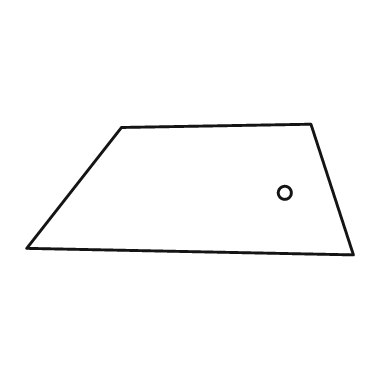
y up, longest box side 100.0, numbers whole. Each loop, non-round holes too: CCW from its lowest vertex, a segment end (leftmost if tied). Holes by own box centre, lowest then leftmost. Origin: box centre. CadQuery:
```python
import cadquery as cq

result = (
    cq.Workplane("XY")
    .moveTo(50.0, -20.0)
    .lineTo(37.0, 20.0)
    .lineTo(-21.0, 19.0)
    .lineTo(-50.0, -18.0)
    .close()
    .moveTo(29.0, -1.0)
    .circle(2.0)
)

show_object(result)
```